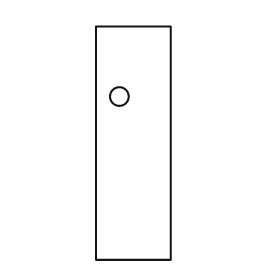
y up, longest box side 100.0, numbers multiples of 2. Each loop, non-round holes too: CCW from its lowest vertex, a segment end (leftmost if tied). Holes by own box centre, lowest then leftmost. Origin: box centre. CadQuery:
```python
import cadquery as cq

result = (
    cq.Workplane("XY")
    .moveTo(-16.0, -50.0)
    .lineTo(16.0, -50.0)
    .lineTo(16.0, 50.0)
    .lineTo(-16.0, 50.0)
    .close()
    .moveTo(-6.0, 20.0)
    .circle(4.0)
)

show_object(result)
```